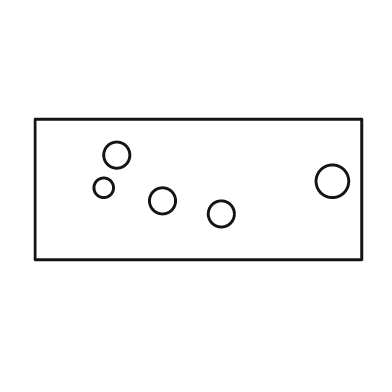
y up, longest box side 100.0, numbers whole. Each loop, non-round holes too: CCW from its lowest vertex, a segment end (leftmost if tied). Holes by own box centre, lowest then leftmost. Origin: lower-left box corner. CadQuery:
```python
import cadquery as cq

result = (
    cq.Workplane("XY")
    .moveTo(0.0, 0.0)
    .lineTo(100.0, 0.0)
    .lineTo(100.0, 43.0)
    .lineTo(0.0, 43.0)
    .close()
    .moveTo(57.0, 14.0)
    .circle(4.0)
    .moveTo(39.0, 18.0)
    .circle(4.0)
    .moveTo(21.0, 22.0)
    .circle(3.0)
    .moveTo(91.0, 24.0)
    .circle(5.0)
    .moveTo(25.0, 32.0)
    .circle(4.0)
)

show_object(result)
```